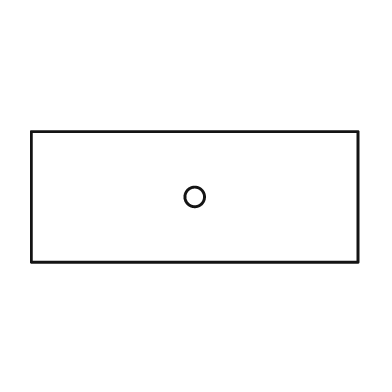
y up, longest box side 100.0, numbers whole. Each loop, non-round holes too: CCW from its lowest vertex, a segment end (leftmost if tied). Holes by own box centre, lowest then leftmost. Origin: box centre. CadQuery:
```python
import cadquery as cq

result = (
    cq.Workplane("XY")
    .moveTo(-50.0, -20.0)
    .lineTo(50.0, -20.0)
    .lineTo(50.0, 20.0)
    .lineTo(-50.0, 20.0)
    .close()
    .moveTo(0.0, 0.0)
    .circle(3.0)
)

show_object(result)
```